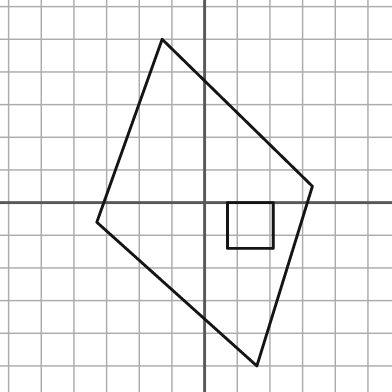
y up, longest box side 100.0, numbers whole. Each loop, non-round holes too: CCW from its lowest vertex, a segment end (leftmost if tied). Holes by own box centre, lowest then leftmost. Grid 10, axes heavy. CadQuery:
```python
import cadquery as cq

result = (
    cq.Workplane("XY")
    .moveTo(16.0, -50.0)
    .lineTo(33.0, 5.0)
    .lineTo(-13.0, 50.0)
    .lineTo(-33.0, -6.0)
    .close()
    .moveTo(7.0, -14.0)
    .lineTo(21.0, -14.0)
    .lineTo(21.0, 0.0)
    .lineTo(7.0, 0.0)
    .close()
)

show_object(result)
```